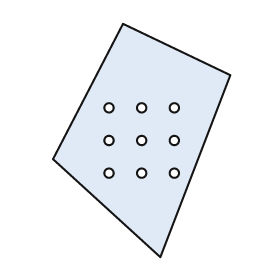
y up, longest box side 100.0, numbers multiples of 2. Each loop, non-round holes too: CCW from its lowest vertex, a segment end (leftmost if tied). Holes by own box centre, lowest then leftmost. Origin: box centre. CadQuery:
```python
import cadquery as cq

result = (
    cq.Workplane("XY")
    .moveTo(8.0, -50.0)
    .lineTo(38.0, 28.0)
    .lineTo(-8.0, 50.0)
    .lineTo(-38.0, -8.0)
    .close()
    .moveTo(-14.0, -14.0)
    .circle(2.0)
    .moveTo(0.0, -14.0)
    .circle(2.0)
    .moveTo(14.0, -14.0)
    .circle(2.0)
    .moveTo(-14.0, 0.0)
    .circle(2.0)
    .moveTo(0.0, 0.0)
    .circle(2.0)
    .moveTo(14.0, 0.0)
    .circle(2.0)
    .moveTo(-14.0, 14.0)
    .circle(2.0)
    .moveTo(0.0, 14.0)
    .circle(2.0)
    .moveTo(14.0, 14.0)
    .circle(2.0)
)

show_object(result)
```